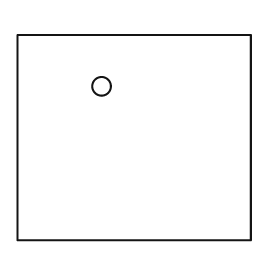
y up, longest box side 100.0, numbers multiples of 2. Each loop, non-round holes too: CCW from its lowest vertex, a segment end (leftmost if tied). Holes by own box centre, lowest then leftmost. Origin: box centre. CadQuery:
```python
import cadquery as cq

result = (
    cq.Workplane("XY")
    .moveTo(-50.0, -44.0)
    .lineTo(50.0, -44.0)
    .lineTo(50.0, 44.0)
    .lineTo(-50.0, 44.0)
    .close()
    .moveTo(-14.0, 22.0)
    .circle(4.0)
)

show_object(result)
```